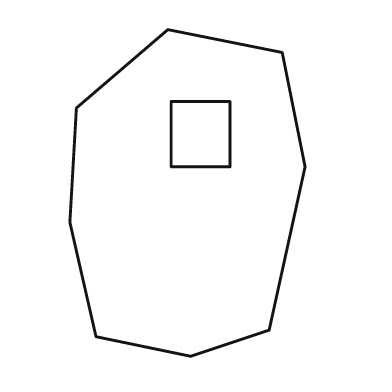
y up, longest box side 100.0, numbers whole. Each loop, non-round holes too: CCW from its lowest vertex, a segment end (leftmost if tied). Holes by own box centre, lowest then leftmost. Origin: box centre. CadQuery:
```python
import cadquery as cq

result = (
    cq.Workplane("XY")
    .moveTo(1.0, -50.0)
    .lineTo(25.0, -42.0)
    .lineTo(36.0, 8.0)
    .lineTo(29.0, 43.0)
    .lineTo(-6.0, 50.0)
    .lineTo(-34.0, 26.0)
    .lineTo(-36.0, -9.0)
    .lineTo(-28.0, -44.0)
    .close()
    .moveTo(-5.0, 8.0)
    .lineTo(13.0, 8.0)
    .lineTo(13.0, 28.0)
    .lineTo(-5.0, 28.0)
    .close()
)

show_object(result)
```